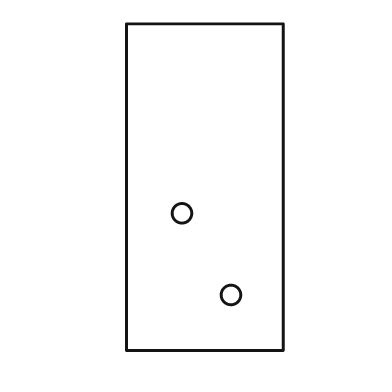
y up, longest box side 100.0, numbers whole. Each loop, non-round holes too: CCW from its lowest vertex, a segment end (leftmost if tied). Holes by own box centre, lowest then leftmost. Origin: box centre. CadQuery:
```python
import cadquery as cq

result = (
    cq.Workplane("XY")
    .moveTo(-24.0, -50.0)
    .lineTo(24.0, -50.0)
    .lineTo(24.0, 50.0)
    .lineTo(-24.0, 50.0)
    .close()
    .moveTo(8.0, -33.0)
    .circle(3.0)
    .moveTo(-7.0, -8.0)
    .circle(3.0)
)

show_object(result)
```